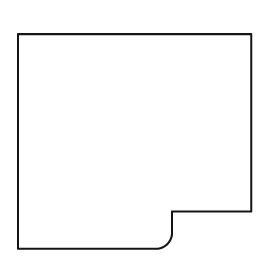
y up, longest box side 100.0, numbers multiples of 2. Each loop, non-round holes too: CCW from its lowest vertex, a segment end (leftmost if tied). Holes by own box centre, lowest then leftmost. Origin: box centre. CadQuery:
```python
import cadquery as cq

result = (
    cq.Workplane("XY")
    .moveTo(-50.0, -46.0)
    .lineTo(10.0, -46.0)
    .threePointArc((14.0, -44.0), (16.0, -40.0))
    .lineTo(16.0, -30.0)
    .lineTo(50.0, -30.0)
    .lineTo(50.0, 46.0)
    .lineTo(-50.0, 46.0)
    .close()
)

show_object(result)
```